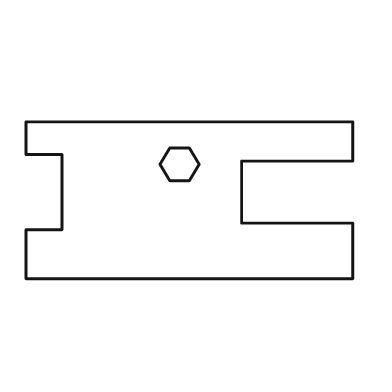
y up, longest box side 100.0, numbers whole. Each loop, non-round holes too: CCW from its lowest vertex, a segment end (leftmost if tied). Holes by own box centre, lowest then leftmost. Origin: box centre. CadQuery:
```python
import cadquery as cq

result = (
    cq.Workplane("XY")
    .moveTo(-50.0, -24.0)
    .lineTo(50.0, -24.0)
    .lineTo(50.0, -7.0)
    .lineTo(16.0, -7.0)
    .lineTo(16.0, 12.0)
    .lineTo(50.0, 12.0)
    .lineTo(50.0, 24.0)
    .lineTo(-50.0, 24.0)
    .lineTo(-50.0, 14.0)
    .lineTo(-39.0, 14.0)
    .lineTo(-39.0, -9.0)
    .lineTo(-50.0, -9.0)
    .close()
    .moveTo(-6.0, 6.0)
    .lineTo(0.0, 6.0)
    .lineTo(3.0, 11.0)
    .lineTo(0.0, 16.0)
    .lineTo(-6.0, 16.0)
    .lineTo(-9.0, 11.0)
    .close()
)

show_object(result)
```